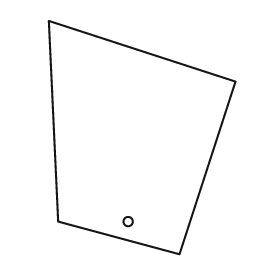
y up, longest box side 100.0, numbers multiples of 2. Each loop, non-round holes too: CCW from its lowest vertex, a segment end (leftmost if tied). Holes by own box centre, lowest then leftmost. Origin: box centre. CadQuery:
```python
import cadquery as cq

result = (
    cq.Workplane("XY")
    .moveTo(16.0, -50.0)
    .lineTo(40.0, 24.0)
    .lineTo(-40.0, 50.0)
    .lineTo(-36.0, -36.0)
    .close()
    .moveTo(-6.0, -36.0)
    .circle(2.0)
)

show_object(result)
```